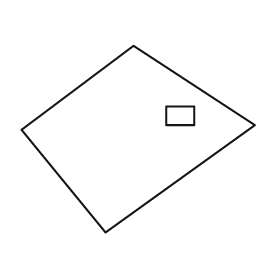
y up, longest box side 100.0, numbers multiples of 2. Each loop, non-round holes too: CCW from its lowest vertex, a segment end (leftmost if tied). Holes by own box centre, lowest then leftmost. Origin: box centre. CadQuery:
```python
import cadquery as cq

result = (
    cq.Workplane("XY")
    .moveTo(-14.0, -40.0)
    .lineTo(50.0, 6.0)
    .lineTo(-2.0, 40.0)
    .lineTo(-50.0, 4.0)
    .close()
    .moveTo(12.0, 6.0)
    .lineTo(24.0, 6.0)
    .lineTo(24.0, 14.0)
    .lineTo(12.0, 14.0)
    .close()
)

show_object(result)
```